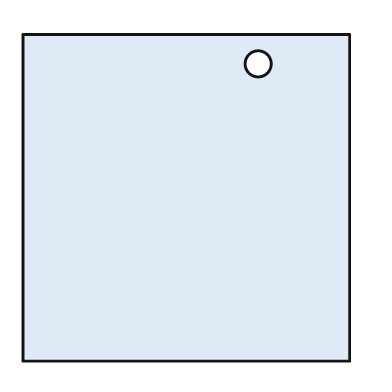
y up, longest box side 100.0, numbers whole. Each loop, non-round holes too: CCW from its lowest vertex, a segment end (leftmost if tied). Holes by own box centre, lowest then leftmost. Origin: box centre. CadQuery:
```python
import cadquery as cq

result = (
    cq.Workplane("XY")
    .moveTo(-50.0, -50.0)
    .lineTo(50.0, -50.0)
    .lineTo(50.0, 50.0)
    .lineTo(-50.0, 50.0)
    .close()
    .moveTo(22.0, 41.0)
    .circle(4.0)
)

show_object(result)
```